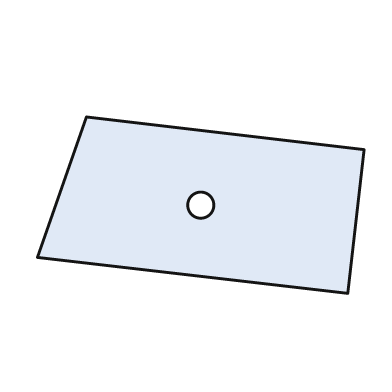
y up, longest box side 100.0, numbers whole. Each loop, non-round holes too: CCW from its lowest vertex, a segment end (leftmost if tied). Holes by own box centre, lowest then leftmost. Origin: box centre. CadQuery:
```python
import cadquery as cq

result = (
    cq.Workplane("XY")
    .moveTo(45.0, -27.0)
    .lineTo(50.0, 17.0)
    .lineTo(-35.0, 27.0)
    .lineTo(-50.0, -16.0)
    .close()
    .moveTo(0.0, 0.0)
    .circle(4.0)
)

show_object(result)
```